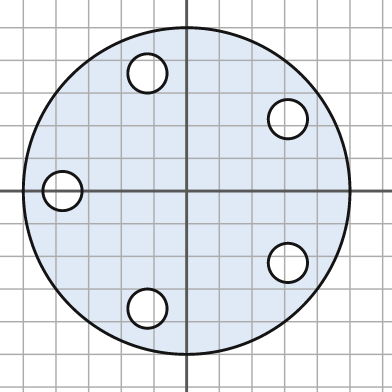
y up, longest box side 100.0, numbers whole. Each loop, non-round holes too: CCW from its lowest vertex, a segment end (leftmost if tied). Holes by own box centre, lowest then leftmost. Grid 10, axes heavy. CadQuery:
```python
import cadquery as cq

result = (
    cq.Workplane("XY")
    .moveTo(0.0, 0.0)
    .circle(50.0)
    .moveTo(-12.0, -36.0)
    .circle(6.0)
    .moveTo(31.0, -22.0)
    .circle(6.0)
    .moveTo(-38.0, 0.0)
    .circle(6.0)
    .moveTo(31.0, 22.0)
    .circle(6.0)
    .moveTo(-12.0, 36.0)
    .circle(6.0)
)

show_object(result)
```